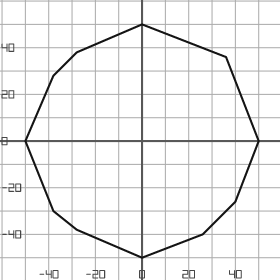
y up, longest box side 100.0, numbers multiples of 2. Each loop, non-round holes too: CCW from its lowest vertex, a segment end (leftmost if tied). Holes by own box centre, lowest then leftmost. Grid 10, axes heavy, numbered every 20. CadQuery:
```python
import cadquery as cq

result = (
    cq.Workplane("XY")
    .moveTo(0.0, -50.0)
    .lineTo(26.0, -40.0)
    .lineTo(40.0, -26.0)
    .lineTo(50.0, 0.0)
    .lineTo(36.0, 36.0)
    .lineTo(0.0, 50.0)
    .lineTo(-28.0, 38.0)
    .lineTo(-38.0, 28.0)
    .lineTo(-50.0, 0.0)
    .lineTo(-38.0, -30.0)
    .lineTo(-28.0, -38.0)
    .close()
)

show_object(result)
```